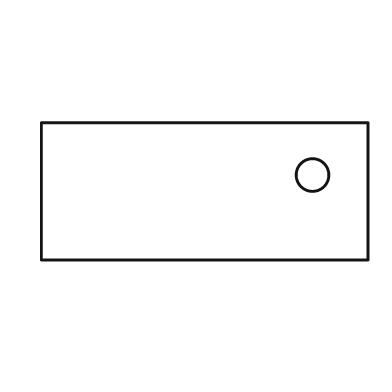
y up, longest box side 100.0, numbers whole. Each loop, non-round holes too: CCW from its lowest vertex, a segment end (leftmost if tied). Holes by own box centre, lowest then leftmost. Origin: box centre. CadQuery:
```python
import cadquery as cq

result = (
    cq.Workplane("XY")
    .moveTo(-50.0, -21.0)
    .lineTo(50.0, -21.0)
    .lineTo(50.0, 21.0)
    .lineTo(-50.0, 21.0)
    .close()
    .moveTo(33.0, 5.0)
    .circle(5.0)
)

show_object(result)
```